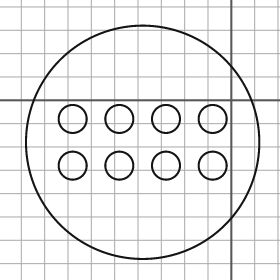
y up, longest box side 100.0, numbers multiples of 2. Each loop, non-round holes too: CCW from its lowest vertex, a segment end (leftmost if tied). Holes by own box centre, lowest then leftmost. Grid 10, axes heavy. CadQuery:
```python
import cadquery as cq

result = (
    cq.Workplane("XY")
    .moveTo(-38.0, -18.0)
    .circle(50.0)
    .moveTo(-68.0, -28.0)
    .circle(6.0)
    .moveTo(-48.0, -28.0)
    .circle(6.0)
    .moveTo(-28.0, -28.0)
    .circle(6.0)
    .moveTo(-8.0, -28.0)
    .circle(6.0)
    .moveTo(-68.0, -8.0)
    .circle(6.0)
    .moveTo(-48.0, -8.0)
    .circle(6.0)
    .moveTo(-28.0, -8.0)
    .circle(6.0)
    .moveTo(-8.0, -8.0)
    .circle(6.0)
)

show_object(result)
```